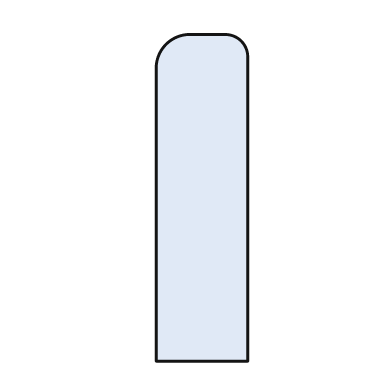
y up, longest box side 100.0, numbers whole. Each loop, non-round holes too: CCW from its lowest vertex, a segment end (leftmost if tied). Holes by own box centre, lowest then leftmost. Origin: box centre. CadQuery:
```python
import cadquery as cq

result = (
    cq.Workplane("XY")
    .moveTo(-14.0, -50.0)
    .lineTo(14.0, -50.0)
    .lineTo(14.0, 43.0)
    .threePointArc((12.0, 48.0), (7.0, 50.0))
    .lineTo(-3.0, 50.0)
    .threePointArc((-11.0, 47.0), (-14.0, 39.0))
    .close()
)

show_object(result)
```